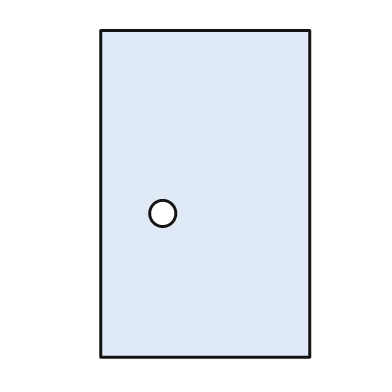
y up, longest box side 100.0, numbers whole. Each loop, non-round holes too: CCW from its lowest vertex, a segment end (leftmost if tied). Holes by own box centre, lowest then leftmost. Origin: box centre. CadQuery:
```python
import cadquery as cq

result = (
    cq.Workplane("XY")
    .moveTo(-32.0, -50.0)
    .lineTo(32.0, -50.0)
    .lineTo(32.0, 50.0)
    .lineTo(-32.0, 50.0)
    .close()
    .moveTo(-13.0, -6.0)
    .circle(4.0)
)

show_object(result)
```